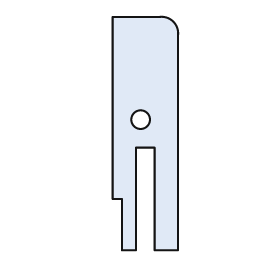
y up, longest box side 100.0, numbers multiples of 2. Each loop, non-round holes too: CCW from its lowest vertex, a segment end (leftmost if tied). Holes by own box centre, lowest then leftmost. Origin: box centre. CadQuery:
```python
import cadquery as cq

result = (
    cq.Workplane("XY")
    .moveTo(-10.0, -50.0)
    .lineTo(-4.0, -50.0)
    .lineTo(-4.0, -6.0)
    .lineTo(4.0, -6.0)
    .lineTo(4.0, -50.0)
    .lineTo(14.0, -50.0)
    .lineTo(14.0, 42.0)
    .threePointArc((12.0, 48.0), (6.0, 50.0))
    .lineTo(-14.0, 50.0)
    .lineTo(-14.0, -28.0)
    .lineTo(-10.0, -28.0)
    .close()
    .moveTo(-2.0, 6.0)
    .circle(4.0)
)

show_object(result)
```